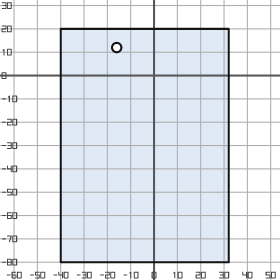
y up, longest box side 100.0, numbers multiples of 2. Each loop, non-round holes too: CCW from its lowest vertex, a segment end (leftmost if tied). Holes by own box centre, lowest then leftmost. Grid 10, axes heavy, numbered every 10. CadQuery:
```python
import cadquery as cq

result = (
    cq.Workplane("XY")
    .moveTo(-40.0, -80.0)
    .lineTo(32.0, -80.0)
    .lineTo(32.0, 20.0)
    .lineTo(-40.0, 20.0)
    .close()
    .moveTo(-16.0, 12.0)
    .circle(2.0)
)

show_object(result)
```